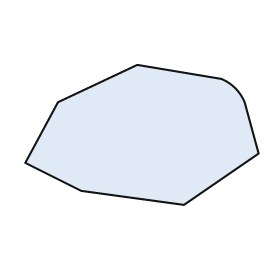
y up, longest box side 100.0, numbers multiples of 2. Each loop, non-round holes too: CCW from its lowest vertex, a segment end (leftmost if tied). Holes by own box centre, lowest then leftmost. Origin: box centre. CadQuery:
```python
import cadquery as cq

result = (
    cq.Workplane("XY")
    .moveTo(18.0, -30.0)
    .lineTo(50.0, -8.0)
    .lineTo(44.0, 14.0)
    .threePointArc((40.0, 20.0), (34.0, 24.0))
    .lineTo(-2.0, 30.0)
    .lineTo(-36.0, 14.0)
    .lineTo(-50.0, -12.0)
    .lineTo(-26.0, -24.0)
    .close()
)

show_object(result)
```